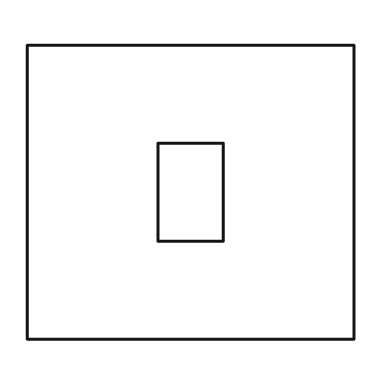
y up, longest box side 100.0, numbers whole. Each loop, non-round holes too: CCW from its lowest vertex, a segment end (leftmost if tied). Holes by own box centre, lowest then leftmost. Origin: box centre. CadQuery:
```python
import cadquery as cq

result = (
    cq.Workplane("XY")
    .moveTo(-50.0, -45.0)
    .lineTo(50.0, -45.0)
    .lineTo(50.0, 45.0)
    .lineTo(-50.0, 45.0)
    .close()
    .moveTo(-10.0, -15.0)
    .lineTo(10.0, -15.0)
    .lineTo(10.0, 15.0)
    .lineTo(-10.0, 15.0)
    .close()
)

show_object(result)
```